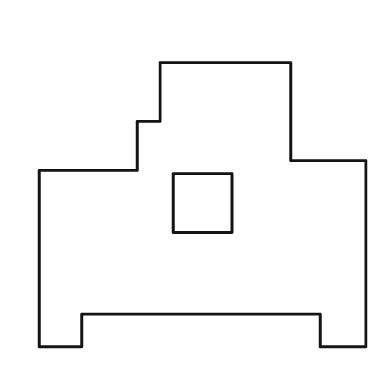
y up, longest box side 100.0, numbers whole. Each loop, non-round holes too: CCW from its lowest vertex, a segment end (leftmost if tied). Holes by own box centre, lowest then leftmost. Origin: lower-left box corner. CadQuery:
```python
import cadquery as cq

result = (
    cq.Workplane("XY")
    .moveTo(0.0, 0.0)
    .lineTo(13.0, 0.0)
    .lineTo(13.0, 10.0)
    .lineTo(86.0, 10.0)
    .lineTo(86.0, 0.0)
    .lineTo(100.0, 0.0)
    .lineTo(100.0, 57.0)
    .lineTo(77.0, 57.0)
    .lineTo(77.0, 87.0)
    .lineTo(37.0, 87.0)
    .lineTo(37.0, 69.0)
    .lineTo(30.0, 69.0)
    .lineTo(30.0, 54.0)
    .lineTo(0.0, 54.0)
    .close()
    .moveTo(41.0, 35.0)
    .lineTo(59.0, 35.0)
    .lineTo(59.0, 53.0)
    .lineTo(41.0, 53.0)
    .close()
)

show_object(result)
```